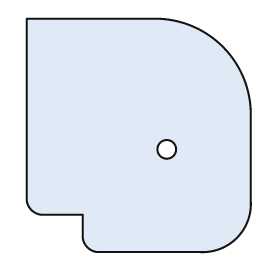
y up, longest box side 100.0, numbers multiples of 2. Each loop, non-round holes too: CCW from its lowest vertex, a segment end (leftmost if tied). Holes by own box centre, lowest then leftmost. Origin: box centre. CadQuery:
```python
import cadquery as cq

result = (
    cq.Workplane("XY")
    .moveTo(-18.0, -50.0)
    .lineTo(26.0, -50.0)
    .threePointArc((42.0, -44.0), (48.0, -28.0))
    .lineTo(48.0, 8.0)
    .threePointArc((36.0, 38.0), (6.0, 50.0))
    .lineTo(-48.0, 50.0)
    .lineTo(-48.0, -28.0)
    .threePointArc((-46.0, -32.0), (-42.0, -34.0))
    .lineTo(-24.0, -34.0)
    .lineTo(-24.0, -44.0)
    .threePointArc((-22.0, -48.0), (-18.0, -50.0))
    .close()
    .moveTo(12.0, -6.0)
    .circle(4.0)
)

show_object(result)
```